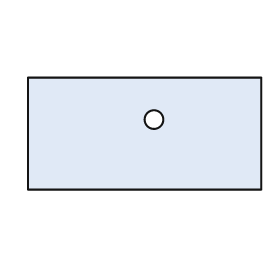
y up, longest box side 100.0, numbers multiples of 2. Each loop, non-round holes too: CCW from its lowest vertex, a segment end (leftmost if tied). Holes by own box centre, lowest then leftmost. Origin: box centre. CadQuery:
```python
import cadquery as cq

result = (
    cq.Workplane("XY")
    .moveTo(-50.0, -24.0)
    .lineTo(50.0, -24.0)
    .lineTo(50.0, 24.0)
    .lineTo(-50.0, 24.0)
    .close()
    .moveTo(4.0, 6.0)
    .circle(4.0)
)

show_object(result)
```